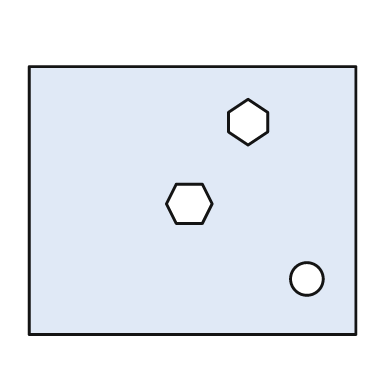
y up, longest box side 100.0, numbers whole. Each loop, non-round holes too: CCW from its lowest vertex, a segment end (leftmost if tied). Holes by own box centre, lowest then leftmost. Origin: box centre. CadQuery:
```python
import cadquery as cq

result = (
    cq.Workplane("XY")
    .moveTo(-50.0, -41.0)
    .lineTo(50.0, -41.0)
    .lineTo(50.0, 41.0)
    .lineTo(-50.0, 41.0)
    .close()
    .moveTo(35.0, -24.0)
    .circle(5.0)
    .moveTo(-5.0, -7.0)
    .lineTo(3.0, -7.0)
    .lineTo(6.0, -1.0)
    .lineTo(3.0, 5.0)
    .lineTo(-5.0, 5.0)
    .lineTo(-8.0, -1.0)
    .close()
    .moveTo(17.0, 17.0)
    .lineTo(23.0, 21.0)
    .lineTo(23.0, 27.0)
    .lineTo(17.0, 31.0)
    .lineTo(11.0, 27.0)
    .lineTo(11.0, 21.0)
    .close()
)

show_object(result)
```